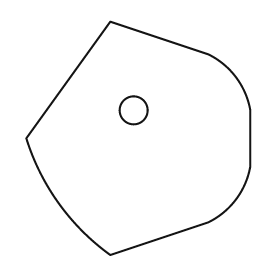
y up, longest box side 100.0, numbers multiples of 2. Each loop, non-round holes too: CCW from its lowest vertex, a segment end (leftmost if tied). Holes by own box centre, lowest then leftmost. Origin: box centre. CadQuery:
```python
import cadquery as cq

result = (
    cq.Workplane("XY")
    .moveTo(-12.0, -50.0)
    .lineTo(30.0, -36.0)
    .threePointArc((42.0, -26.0), (48.0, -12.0))
    .lineTo(48.0, 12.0)
    .threePointArc((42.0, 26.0), (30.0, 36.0))
    .lineTo(-12.0, 50.0)
    .lineTo(-48.0, 0.0)
    .threePointArc((-34.0, -28.0), (-12.0, -50.0))
    .close()
    .moveTo(-2.0, 12.0)
    .circle(6.0)
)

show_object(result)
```